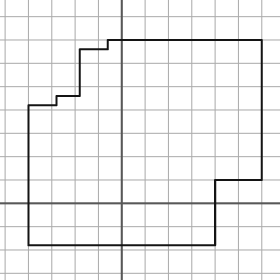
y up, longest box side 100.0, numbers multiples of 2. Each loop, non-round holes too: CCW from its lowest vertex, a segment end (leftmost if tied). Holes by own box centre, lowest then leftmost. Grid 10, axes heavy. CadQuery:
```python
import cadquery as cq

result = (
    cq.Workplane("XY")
    .moveTo(-40.0, -18.0)
    .lineTo(40.0, -18.0)
    .lineTo(40.0, 10.0)
    .lineTo(60.0, 10.0)
    .lineTo(60.0, 70.0)
    .lineTo(-6.0, 70.0)
    .lineTo(-6.0, 66.0)
    .lineTo(-18.0, 66.0)
    .lineTo(-18.0, 46.0)
    .lineTo(-28.0, 46.0)
    .lineTo(-28.0, 42.0)
    .lineTo(-40.0, 42.0)
    .close()
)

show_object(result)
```